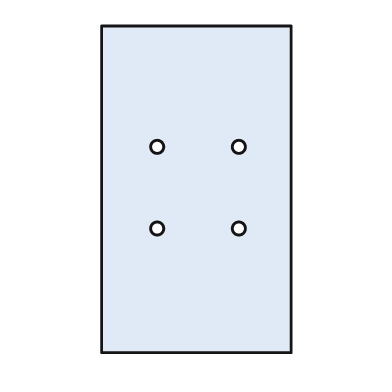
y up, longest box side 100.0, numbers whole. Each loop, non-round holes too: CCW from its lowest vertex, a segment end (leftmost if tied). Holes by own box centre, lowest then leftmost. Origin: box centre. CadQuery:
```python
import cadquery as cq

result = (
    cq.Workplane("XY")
    .moveTo(-29.0, -50.0)
    .lineTo(29.0, -50.0)
    .lineTo(29.0, 50.0)
    .lineTo(-29.0, 50.0)
    .close()
    .moveTo(-12.0, -12.0)
    .circle(2.0)
    .moveTo(13.0, -12.0)
    .circle(2.0)
    .moveTo(-12.0, 13.0)
    .circle(2.0)
    .moveTo(13.0, 13.0)
    .circle(2.0)
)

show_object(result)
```